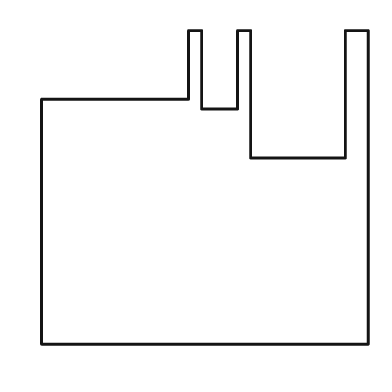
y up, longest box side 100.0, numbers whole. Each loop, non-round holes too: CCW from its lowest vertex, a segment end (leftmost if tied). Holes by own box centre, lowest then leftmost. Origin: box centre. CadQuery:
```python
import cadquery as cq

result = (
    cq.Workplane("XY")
    .moveTo(-50.0, -48.0)
    .lineTo(50.0, -48.0)
    .lineTo(50.0, 48.0)
    .lineTo(43.0, 48.0)
    .lineTo(43.0, 9.0)
    .lineTo(14.0, 9.0)
    .lineTo(14.0, 48.0)
    .lineTo(10.0, 48.0)
    .lineTo(10.0, 24.0)
    .lineTo(-1.0, 24.0)
    .lineTo(-1.0, 48.0)
    .lineTo(-5.0, 48.0)
    .lineTo(-5.0, 27.0)
    .lineTo(-50.0, 27.0)
    .close()
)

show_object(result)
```